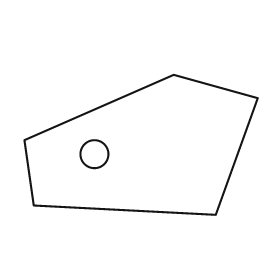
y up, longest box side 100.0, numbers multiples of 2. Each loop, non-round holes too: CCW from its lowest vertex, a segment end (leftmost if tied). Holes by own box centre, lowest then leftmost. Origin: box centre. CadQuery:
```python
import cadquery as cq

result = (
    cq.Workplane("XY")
    .moveTo(32.0, -30.0)
    .lineTo(50.0, 20.0)
    .lineTo(14.0, 30.0)
    .lineTo(-50.0, 2.0)
    .lineTo(-46.0, -26.0)
    .close()
    .moveTo(-20.0, -4.0)
    .circle(6.0)
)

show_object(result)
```